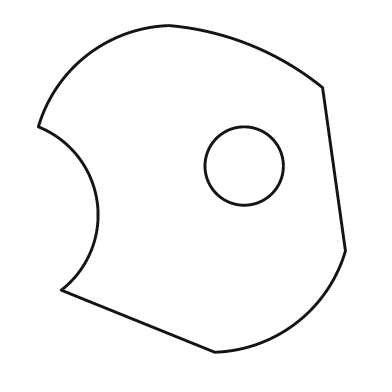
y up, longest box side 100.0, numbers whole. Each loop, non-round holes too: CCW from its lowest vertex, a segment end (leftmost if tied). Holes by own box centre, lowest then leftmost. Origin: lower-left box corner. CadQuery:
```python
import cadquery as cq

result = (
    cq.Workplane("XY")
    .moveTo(54.0, 0.0)
    .threePointArc((79.0, 9.0), (94.0, 31.0))
    .lineTo(87.0, 81.0)
    .threePointArc((65.0, 94.0), (40.0, 100.0))
    .threePointArc((15.0, 91.0), (0.0, 69.0))
    .threePointArc((18.0, 46.0), (7.0, 19.0))
    .close()
    .moveTo(63.0, 57.0)
    .circle(12.0)
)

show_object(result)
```